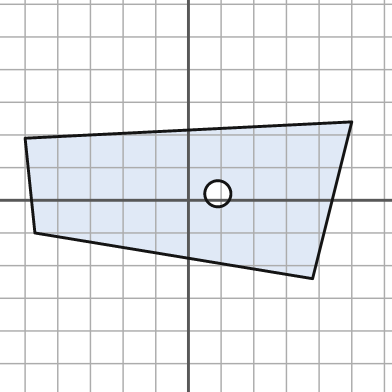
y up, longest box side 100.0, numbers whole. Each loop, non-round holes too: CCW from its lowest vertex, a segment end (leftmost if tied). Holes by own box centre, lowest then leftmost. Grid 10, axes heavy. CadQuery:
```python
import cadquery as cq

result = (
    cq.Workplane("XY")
    .moveTo(38.0, -24.0)
    .lineTo(50.0, 24.0)
    .lineTo(-50.0, 19.0)
    .lineTo(-47.0, -10.0)
    .close()
    .moveTo(9.0, 2.0)
    .circle(4.0)
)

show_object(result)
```